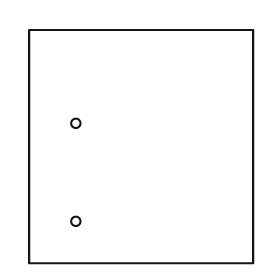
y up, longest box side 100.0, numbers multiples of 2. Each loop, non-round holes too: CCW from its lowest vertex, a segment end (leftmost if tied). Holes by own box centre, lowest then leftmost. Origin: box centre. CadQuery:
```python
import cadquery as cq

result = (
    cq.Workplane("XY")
    .moveTo(-48.0, -50.0)
    .lineTo(48.0, -50.0)
    .lineTo(48.0, 50.0)
    .lineTo(-48.0, 50.0)
    .close()
    .moveTo(-28.0, -32.0)
    .circle(2.0)
    .moveTo(-28.0, 10.0)
    .circle(2.0)
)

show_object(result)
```